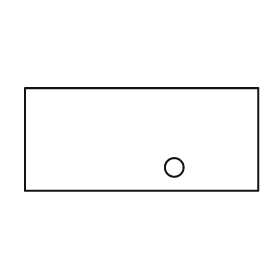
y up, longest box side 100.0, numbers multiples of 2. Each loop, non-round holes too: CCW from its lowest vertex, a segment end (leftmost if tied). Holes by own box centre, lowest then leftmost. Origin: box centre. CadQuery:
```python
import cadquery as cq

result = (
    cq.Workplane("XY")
    .moveTo(-50.0, -22.0)
    .lineTo(50.0, -22.0)
    .lineTo(50.0, 22.0)
    .lineTo(-50.0, 22.0)
    .close()
    .moveTo(14.0, -12.0)
    .circle(4.0)
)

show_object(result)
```